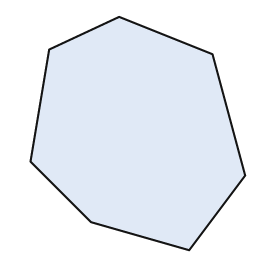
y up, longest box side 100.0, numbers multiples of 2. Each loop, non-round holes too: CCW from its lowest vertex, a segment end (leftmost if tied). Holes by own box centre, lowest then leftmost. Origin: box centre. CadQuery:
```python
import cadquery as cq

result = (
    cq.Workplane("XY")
    .moveTo(22.0, -50.0)
    .lineTo(46.0, -18.0)
    .lineTo(32.0, 34.0)
    .lineTo(-8.0, 50.0)
    .lineTo(-38.0, 36.0)
    .lineTo(-46.0, -12.0)
    .lineTo(-20.0, -38.0)
    .close()
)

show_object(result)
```